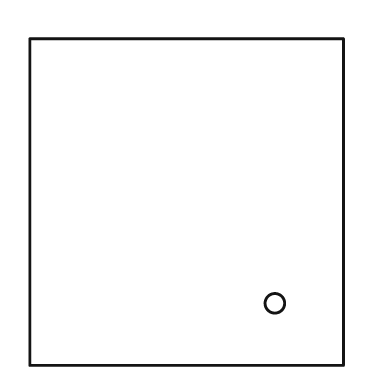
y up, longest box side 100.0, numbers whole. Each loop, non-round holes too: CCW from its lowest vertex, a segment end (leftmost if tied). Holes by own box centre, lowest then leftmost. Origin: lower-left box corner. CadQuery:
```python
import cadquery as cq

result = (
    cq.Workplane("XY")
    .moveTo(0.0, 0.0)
    .lineTo(96.0, 0.0)
    .lineTo(96.0, 100.0)
    .lineTo(0.0, 100.0)
    .close()
    .moveTo(75.0, 19.0)
    .circle(3.0)
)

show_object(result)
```